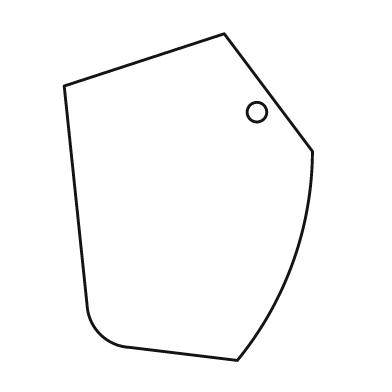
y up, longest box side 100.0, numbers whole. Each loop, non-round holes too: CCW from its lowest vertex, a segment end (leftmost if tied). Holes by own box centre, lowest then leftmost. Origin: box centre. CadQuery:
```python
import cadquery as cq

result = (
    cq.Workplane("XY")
    .moveTo(15.0, -50.0)
    .threePointArc((32.0, -20.0), (38.0, 14.0))
    .lineTo(11.0, 50.0)
    .lineTo(-38.0, 34.0)
    .lineTo(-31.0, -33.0)
    .threePointArc((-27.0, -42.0), (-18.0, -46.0))
    .close()
    .moveTo(21.0, 26.0)
    .circle(3.0)
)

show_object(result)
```